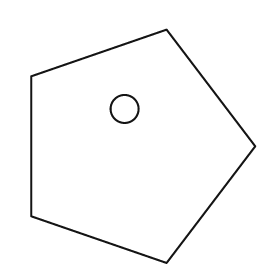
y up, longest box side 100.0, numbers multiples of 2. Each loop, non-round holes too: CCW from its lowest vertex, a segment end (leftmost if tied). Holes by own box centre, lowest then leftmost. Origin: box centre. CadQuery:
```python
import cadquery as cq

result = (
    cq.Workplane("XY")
    .moveTo(10.0, -50.0)
    .lineTo(48.0, 0.0)
    .lineTo(10.0, 50.0)
    .lineTo(-48.0, 30.0)
    .lineTo(-48.0, -30.0)
    .close()
    .moveTo(-8.0, 16.0)
    .circle(6.0)
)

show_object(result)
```